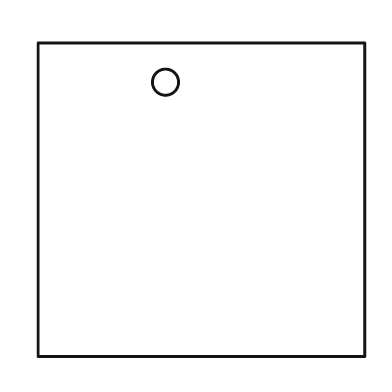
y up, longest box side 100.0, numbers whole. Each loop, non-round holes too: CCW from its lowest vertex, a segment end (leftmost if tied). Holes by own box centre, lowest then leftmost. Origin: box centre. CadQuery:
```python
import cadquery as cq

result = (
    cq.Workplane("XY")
    .moveTo(-50.0, -48.0)
    .lineTo(50.0, -48.0)
    .lineTo(50.0, 48.0)
    .lineTo(-50.0, 48.0)
    .close()
    .moveTo(-11.0, 36.0)
    .circle(4.0)
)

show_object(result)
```